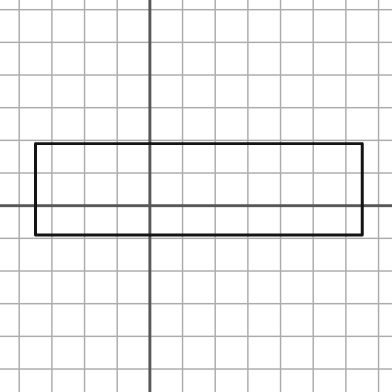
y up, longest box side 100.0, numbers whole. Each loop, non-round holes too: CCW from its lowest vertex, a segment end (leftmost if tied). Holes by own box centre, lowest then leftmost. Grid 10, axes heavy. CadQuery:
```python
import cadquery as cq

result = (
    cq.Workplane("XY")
    .moveTo(-35.0, -9.0)
    .lineTo(65.0, -9.0)
    .lineTo(65.0, 19.0)
    .lineTo(-35.0, 19.0)
    .close()
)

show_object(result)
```